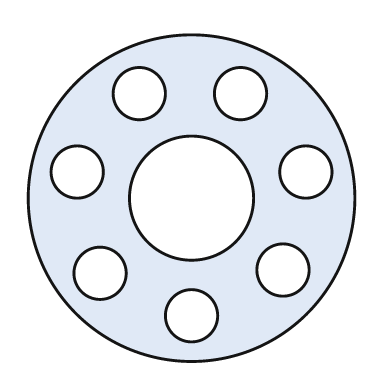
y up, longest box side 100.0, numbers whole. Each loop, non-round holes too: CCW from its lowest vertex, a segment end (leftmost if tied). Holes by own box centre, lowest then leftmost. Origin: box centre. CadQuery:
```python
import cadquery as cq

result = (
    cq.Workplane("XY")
    .moveTo(0.0, 0.0)
    .circle(50.0)
    .moveTo(0.0, -36.0)
    .circle(8.0)
    .moveTo(-28.0, -23.0)
    .circle(8.0)
    .moveTo(28.0, -22.0)
    .circle(8.0)
    .moveTo(0.0, 0.0)
    .circle(19.0)
    .moveTo(-35.0, 8.0)
    .circle(8.0)
    .moveTo(35.0, 8.0)
    .circle(8.0)
    .moveTo(-16.0, 32.0)
    .circle(8.0)
    .moveTo(15.0, 32.0)
    .circle(8.0)
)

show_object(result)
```